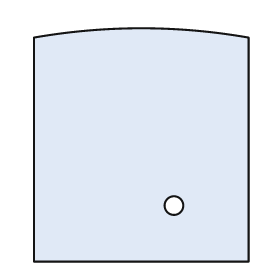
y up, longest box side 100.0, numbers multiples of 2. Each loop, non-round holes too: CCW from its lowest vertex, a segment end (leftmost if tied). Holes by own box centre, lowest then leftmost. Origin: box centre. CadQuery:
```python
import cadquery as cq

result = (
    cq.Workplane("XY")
    .moveTo(-46.0, -50.0)
    .lineTo(46.0, -50.0)
    .lineTo(46.0, 46.0)
    .threePointArc((0.0, 50.0), (-46.0, 46.0))
    .close()
    .moveTo(14.0, -26.0)
    .circle(4.0)
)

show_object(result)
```